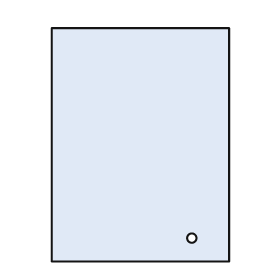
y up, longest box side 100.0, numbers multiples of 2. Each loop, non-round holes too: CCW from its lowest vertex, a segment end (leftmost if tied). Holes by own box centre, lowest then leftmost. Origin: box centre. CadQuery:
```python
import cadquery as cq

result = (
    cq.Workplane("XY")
    .moveTo(-38.0, -50.0)
    .lineTo(38.0, -50.0)
    .lineTo(38.0, 50.0)
    .lineTo(-38.0, 50.0)
    .close()
    .moveTo(22.0, -40.0)
    .circle(2.0)
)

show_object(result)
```